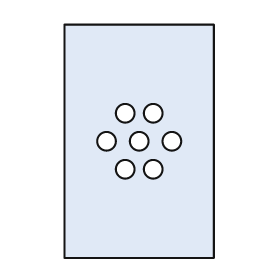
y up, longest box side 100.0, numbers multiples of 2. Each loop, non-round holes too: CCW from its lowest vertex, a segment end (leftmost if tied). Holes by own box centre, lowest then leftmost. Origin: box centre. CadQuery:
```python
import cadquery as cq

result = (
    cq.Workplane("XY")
    .moveTo(-32.0, -50.0)
    .lineTo(32.0, -50.0)
    .lineTo(32.0, 50.0)
    .lineTo(-32.0, 50.0)
    .close()
    .moveTo(-6.0, -12.0)
    .circle(4.0)
    .moveTo(6.0, -12.0)
    .circle(4.0)
    .moveTo(-14.0, 0.0)
    .circle(4.0)
    .moveTo(0.0, 0.0)
    .circle(4.0)
    .moveTo(14.0, 0.0)
    .circle(4.0)
    .moveTo(-6.0, 12.0)
    .circle(4.0)
    .moveTo(6.0, 12.0)
    .circle(4.0)
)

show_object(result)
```